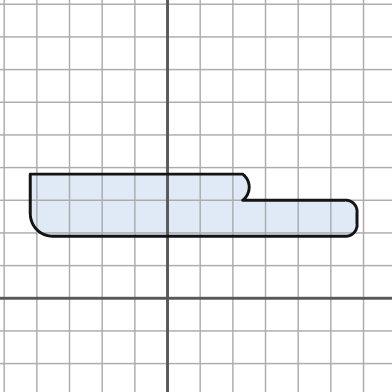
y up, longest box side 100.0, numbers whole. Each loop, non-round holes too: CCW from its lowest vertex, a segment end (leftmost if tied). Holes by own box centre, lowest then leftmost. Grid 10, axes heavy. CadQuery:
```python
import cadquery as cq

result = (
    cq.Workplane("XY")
    .moveTo(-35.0, 19.0)
    .lineTo(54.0, 19.0)
    .threePointArc((57.0, 20.0), (58.0, 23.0))
    .lineTo(58.0, 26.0)
    .threePointArc((57.0, 29.0), (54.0, 30.0))
    .lineTo(23.0, 30.0)
    .threePointArc((25.0, 34.0), (23.0, 38.0))
    .lineTo(-42.0, 38.0)
    .lineTo(-42.0, 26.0)
    .threePointArc((-40.0, 21.0), (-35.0, 19.0))
    .close()
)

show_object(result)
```